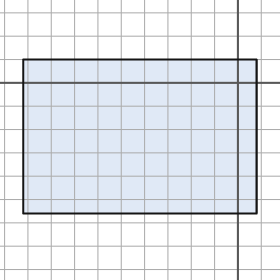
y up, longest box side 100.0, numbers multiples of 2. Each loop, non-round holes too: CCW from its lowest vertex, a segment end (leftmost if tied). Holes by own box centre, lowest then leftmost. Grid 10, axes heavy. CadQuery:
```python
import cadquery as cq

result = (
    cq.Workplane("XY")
    .moveTo(-92.0, -56.0)
    .lineTo(8.0, -56.0)
    .lineTo(8.0, 10.0)
    .lineTo(-92.0, 10.0)
    .close()
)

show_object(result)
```